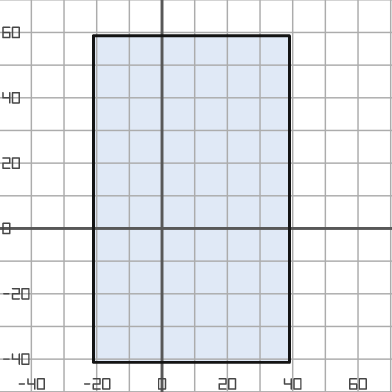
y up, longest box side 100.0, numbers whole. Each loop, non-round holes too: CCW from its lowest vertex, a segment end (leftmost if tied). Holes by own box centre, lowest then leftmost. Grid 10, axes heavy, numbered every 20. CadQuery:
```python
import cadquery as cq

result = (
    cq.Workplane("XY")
    .moveTo(-21.0, -41.0)
    .lineTo(39.0, -41.0)
    .lineTo(39.0, 59.0)
    .lineTo(-21.0, 59.0)
    .close()
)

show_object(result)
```